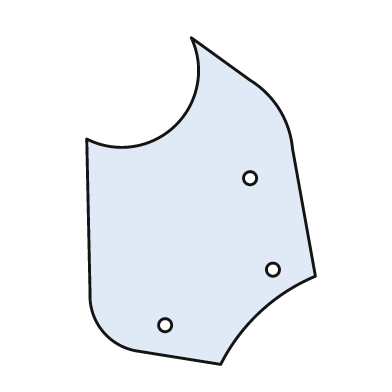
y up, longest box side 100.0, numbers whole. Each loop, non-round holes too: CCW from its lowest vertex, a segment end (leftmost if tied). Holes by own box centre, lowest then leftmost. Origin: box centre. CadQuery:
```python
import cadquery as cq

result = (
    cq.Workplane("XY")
    .moveTo(6.0, -50.0)
    .threePointArc((18.0, -34.0), (35.0, -23.0))
    .lineTo(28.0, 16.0)
    .threePointArc((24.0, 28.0), (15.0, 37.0))
    .lineTo(-3.0, 50.0)
    .threePointArc((-8.0, 23.0), (-35.0, 19.0))
    .lineTo(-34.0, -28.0)
    .threePointArc((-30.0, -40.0), (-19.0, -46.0))
    .close()
    .moveTo(-11.0, -38.0)
    .circle(2.0)
    .moveTo(22.0, -21.0)
    .circle(2.0)
    .moveTo(15.0, 7.0)
    .circle(2.0)
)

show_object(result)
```